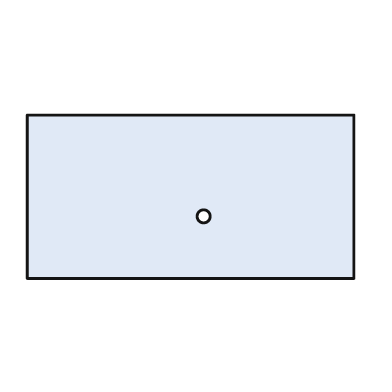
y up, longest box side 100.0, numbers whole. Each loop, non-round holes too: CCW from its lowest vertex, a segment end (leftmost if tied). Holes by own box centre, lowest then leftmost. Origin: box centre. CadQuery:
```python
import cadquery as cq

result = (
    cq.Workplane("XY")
    .moveTo(-50.0, -25.0)
    .lineTo(50.0, -25.0)
    .lineTo(50.0, 25.0)
    .lineTo(-50.0, 25.0)
    .close()
    .moveTo(4.0, -6.0)
    .circle(2.0)
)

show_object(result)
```